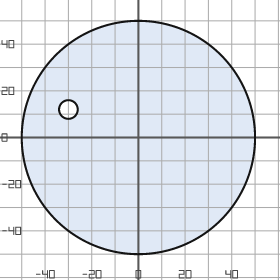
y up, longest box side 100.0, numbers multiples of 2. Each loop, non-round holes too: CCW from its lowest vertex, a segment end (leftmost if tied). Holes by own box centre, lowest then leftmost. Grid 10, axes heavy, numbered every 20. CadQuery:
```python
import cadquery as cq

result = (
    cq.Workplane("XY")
    .moveTo(0.0, 0.0)
    .circle(50.0)
    .moveTo(-30.0, 12.0)
    .circle(4.0)
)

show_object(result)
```